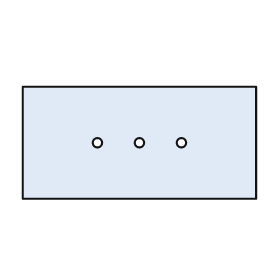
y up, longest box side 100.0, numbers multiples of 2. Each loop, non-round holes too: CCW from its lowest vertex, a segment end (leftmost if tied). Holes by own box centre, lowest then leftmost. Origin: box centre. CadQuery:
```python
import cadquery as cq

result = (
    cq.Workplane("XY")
    .moveTo(-50.0, -24.0)
    .lineTo(50.0, -24.0)
    .lineTo(50.0, 24.0)
    .lineTo(-50.0, 24.0)
    .close()
    .moveTo(-18.0, 0.0)
    .circle(2.0)
    .moveTo(0.0, 0.0)
    .circle(2.0)
    .moveTo(18.0, 0.0)
    .circle(2.0)
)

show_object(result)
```